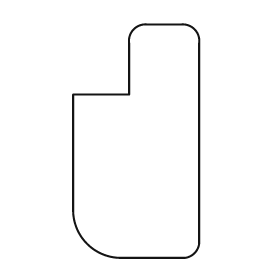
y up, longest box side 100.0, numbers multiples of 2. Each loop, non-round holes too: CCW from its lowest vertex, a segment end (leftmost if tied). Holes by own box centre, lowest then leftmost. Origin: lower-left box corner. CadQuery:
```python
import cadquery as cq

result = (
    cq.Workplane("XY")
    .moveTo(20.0, 0.0)
    .lineTo(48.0, 0.0)
    .threePointArc((52.0, 2.0), (54.0, 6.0))
    .lineTo(54.0, 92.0)
    .threePointArc((52.0, 98.0), (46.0, 100.0))
    .lineTo(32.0, 100.0)
    .threePointArc((26.0, 98.0), (24.0, 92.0))
    .lineTo(24.0, 70.0)
    .lineTo(0.0, 70.0)
    .lineTo(0.0, 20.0)
    .threePointArc((6.0, 6.0), (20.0, 0.0))
    .close()
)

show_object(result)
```